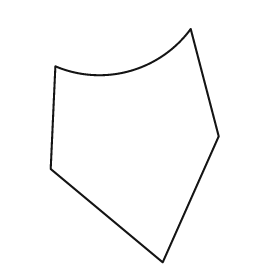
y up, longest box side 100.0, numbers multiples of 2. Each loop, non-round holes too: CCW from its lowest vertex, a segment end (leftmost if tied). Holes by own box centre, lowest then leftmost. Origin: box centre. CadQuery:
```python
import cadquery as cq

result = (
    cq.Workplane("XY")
    .moveTo(12.0, -50.0)
    .lineTo(36.0, 4.0)
    .lineTo(24.0, 50.0)
    .threePointArc((-2.0, 32.0), (-34.0, 34.0))
    .lineTo(-36.0, -10.0)
    .close()
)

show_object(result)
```